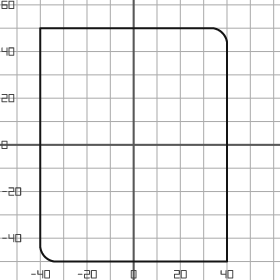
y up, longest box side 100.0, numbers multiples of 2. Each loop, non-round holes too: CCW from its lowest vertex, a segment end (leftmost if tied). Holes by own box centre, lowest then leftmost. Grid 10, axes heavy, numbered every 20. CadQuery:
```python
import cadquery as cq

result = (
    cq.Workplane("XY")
    .moveTo(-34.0, -50.0)
    .lineTo(40.0, -50.0)
    .lineTo(40.0, 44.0)
    .threePointArc((38.0, 48.0), (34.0, 50.0))
    .lineTo(-40.0, 50.0)
    .lineTo(-40.0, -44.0)
    .threePointArc((-38.0, -48.0), (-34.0, -50.0))
    .close()
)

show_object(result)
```